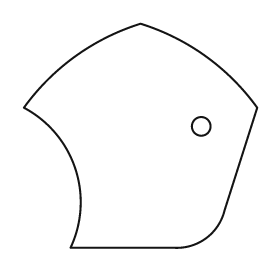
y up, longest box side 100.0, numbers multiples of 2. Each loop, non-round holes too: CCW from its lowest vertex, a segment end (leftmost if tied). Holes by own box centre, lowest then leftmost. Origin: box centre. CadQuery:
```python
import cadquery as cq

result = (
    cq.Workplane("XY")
    .moveTo(-30.0, -48.0)
    .lineTo(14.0, -48.0)
    .threePointArc((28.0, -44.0), (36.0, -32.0))
    .lineTo(50.0, 12.0)
    .threePointArc((28.0, 34.0), (0.0, 48.0))
    .threePointArc((-28.0, 34.0), (-50.0, 12.0))
    .threePointArc((-28.0, -14.0), (-30.0, -48.0))
    .close()
    .moveTo(26.0, 4.0)
    .circle(4.0)
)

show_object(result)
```